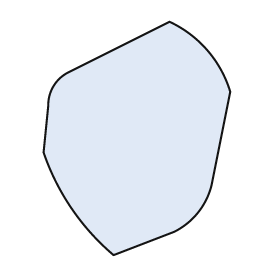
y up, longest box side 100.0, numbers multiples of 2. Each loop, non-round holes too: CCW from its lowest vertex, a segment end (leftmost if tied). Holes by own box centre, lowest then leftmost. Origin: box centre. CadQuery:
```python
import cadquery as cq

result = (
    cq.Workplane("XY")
    .moveTo(-10.0, -50.0)
    .lineTo(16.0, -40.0)
    .threePointArc((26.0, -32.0), (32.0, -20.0))
    .lineTo(40.0, 20.0)
    .threePointArc((30.0, 38.0), (14.0, 50.0))
    .lineTo(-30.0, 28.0)
    .threePointArc((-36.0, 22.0), (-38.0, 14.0))
    .lineTo(-40.0, -6.0)
    .threePointArc((-28.0, -30.0), (-10.0, -50.0))
    .close()
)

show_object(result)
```